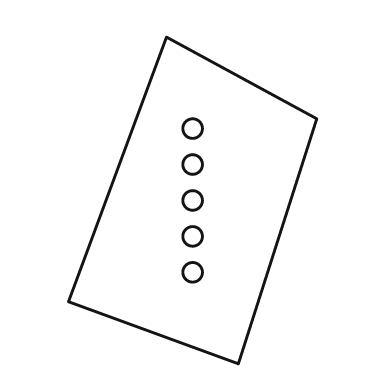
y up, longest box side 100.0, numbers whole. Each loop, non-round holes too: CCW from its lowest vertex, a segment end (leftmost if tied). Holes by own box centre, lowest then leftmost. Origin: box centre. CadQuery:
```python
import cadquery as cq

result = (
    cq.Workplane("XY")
    .moveTo(14.0, -50.0)
    .lineTo(38.0, 25.0)
    .lineTo(-8.0, 50.0)
    .lineTo(-38.0, -31.0)
    .close()
    .moveTo(0.0, -22.0)
    .circle(3.0)
    .moveTo(0.0, -11.0)
    .circle(3.0)
    .moveTo(0.0, 0.0)
    .circle(3.0)
    .moveTo(0.0, 11.0)
    .circle(3.0)
    .moveTo(0.0, 22.0)
    .circle(3.0)
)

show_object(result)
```